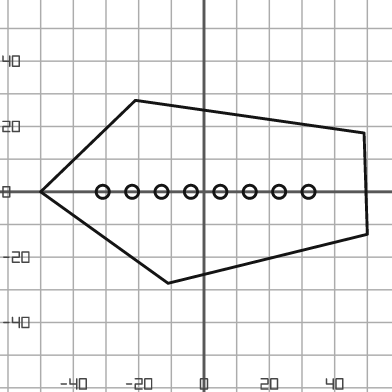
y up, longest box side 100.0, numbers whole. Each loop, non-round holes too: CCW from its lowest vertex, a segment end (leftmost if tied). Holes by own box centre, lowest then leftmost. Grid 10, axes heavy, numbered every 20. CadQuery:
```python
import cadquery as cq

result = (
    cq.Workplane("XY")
    .moveTo(-11.0, -28.0)
    .lineTo(50.0, -13.0)
    .lineTo(49.0, 18.0)
    .lineTo(-21.0, 28.0)
    .lineTo(-50.0, 0.0)
    .close()
    .moveTo(-31.0, 0.0)
    .circle(2.0)
    .moveTo(-22.0, 0.0)
    .circle(2.0)
    .moveTo(-13.0, 0.0)
    .circle(2.0)
    .moveTo(-4.0, 0.0)
    .circle(2.0)
    .moveTo(5.0, 0.0)
    .circle(2.0)
    .moveTo(14.0, 0.0)
    .circle(2.0)
    .moveTo(23.0, 0.0)
    .circle(2.0)
    .moveTo(32.0, 0.0)
    .circle(2.0)
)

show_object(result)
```